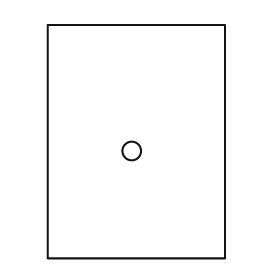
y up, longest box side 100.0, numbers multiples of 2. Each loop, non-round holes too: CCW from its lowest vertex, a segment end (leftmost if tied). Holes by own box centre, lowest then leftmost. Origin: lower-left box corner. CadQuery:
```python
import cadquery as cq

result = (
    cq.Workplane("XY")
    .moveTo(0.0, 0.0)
    .lineTo(76.0, 0.0)
    .lineTo(76.0, 100.0)
    .lineTo(0.0, 100.0)
    .close()
    .moveTo(36.0, 46.0)
    .circle(4.0)
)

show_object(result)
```